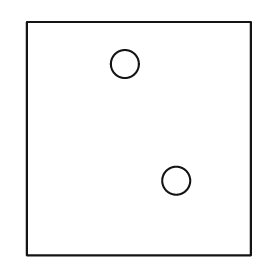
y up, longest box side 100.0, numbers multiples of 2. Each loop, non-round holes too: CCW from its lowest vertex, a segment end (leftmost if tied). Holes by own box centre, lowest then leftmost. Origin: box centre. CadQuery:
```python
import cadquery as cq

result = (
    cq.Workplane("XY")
    .moveTo(-48.0, -50.0)
    .lineTo(48.0, -50.0)
    .lineTo(48.0, 50.0)
    .lineTo(-48.0, 50.0)
    .close()
    .moveTo(16.0, -18.0)
    .circle(6.0)
    .moveTo(-6.0, 32.0)
    .circle(6.0)
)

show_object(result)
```